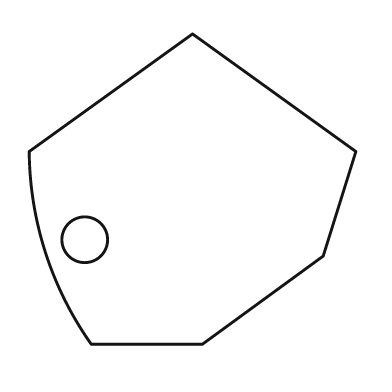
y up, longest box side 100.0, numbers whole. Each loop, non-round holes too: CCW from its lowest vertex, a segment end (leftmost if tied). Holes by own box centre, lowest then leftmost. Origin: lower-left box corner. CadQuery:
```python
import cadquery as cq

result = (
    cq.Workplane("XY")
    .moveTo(19.0, 0.0)
    .lineTo(53.0, 0.0)
    .lineTo(90.0, 27.0)
    .lineTo(100.0, 59.0)
    .lineTo(50.0, 95.0)
    .lineTo(0.0, 59.0)
    .threePointArc((5.0, 28.0), (19.0, 0.0))
    .close()
    .moveTo(17.0, 32.0)
    .circle(7.0)
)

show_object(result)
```